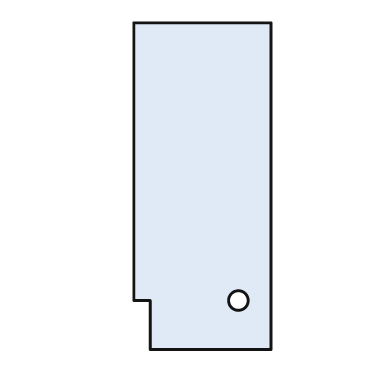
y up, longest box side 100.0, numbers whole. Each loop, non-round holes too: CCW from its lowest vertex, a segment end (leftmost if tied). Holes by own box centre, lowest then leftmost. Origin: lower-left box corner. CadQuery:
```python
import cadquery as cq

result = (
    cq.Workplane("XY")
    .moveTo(5.0, 0.0)
    .lineTo(42.0, 0.0)
    .lineTo(42.0, 100.0)
    .lineTo(0.0, 100.0)
    .lineTo(0.0, 15.0)
    .lineTo(5.0, 15.0)
    .close()
    .moveTo(32.0, 15.0)
    .circle(3.0)
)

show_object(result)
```